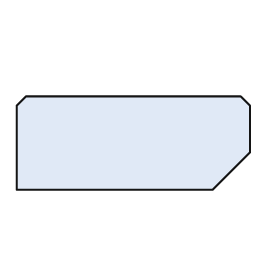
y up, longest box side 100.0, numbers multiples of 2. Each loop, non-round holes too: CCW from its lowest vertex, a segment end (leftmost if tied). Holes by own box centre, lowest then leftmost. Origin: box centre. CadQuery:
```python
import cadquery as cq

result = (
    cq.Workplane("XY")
    .moveTo(-50.0, -20.0)
    .lineTo(34.0, -20.0)
    .lineTo(50.0, -4.0)
    .lineTo(50.0, 16.0)
    .lineTo(46.0, 20.0)
    .lineTo(-46.0, 20.0)
    .lineTo(-50.0, 16.0)
    .close()
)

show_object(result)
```